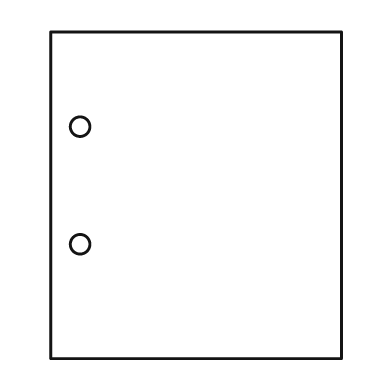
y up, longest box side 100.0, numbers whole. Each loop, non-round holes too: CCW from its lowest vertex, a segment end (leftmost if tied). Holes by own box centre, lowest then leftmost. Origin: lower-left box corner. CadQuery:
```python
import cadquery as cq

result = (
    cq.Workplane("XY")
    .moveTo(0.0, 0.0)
    .lineTo(89.0, 0.0)
    .lineTo(89.0, 100.0)
    .lineTo(0.0, 100.0)
    .close()
    .moveTo(9.0, 35.0)
    .circle(3.0)
    .moveTo(9.0, 71.0)
    .circle(3.0)
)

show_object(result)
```